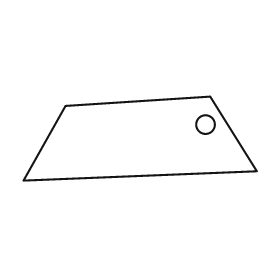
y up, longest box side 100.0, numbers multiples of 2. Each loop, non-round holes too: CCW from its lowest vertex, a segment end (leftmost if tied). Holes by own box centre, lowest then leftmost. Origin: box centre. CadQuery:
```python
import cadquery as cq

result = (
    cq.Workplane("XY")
    .moveTo(-50.0, -18.0)
    .lineTo(50.0, -14.0)
    .lineTo(30.0, 18.0)
    .lineTo(-32.0, 14.0)
    .close()
    .moveTo(28.0, 6.0)
    .circle(4.0)
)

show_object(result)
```